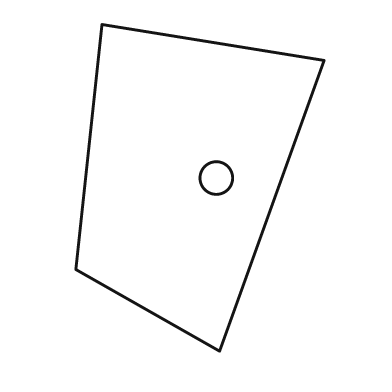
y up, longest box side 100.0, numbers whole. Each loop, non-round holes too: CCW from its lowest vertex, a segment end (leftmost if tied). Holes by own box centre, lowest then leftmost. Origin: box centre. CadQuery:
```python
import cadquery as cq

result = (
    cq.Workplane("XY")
    .moveTo(6.0, -50.0)
    .lineTo(38.0, 39.0)
    .lineTo(-30.0, 50.0)
    .lineTo(-38.0, -25.0)
    .close()
    .moveTo(5.0, 3.0)
    .circle(5.0)
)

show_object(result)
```